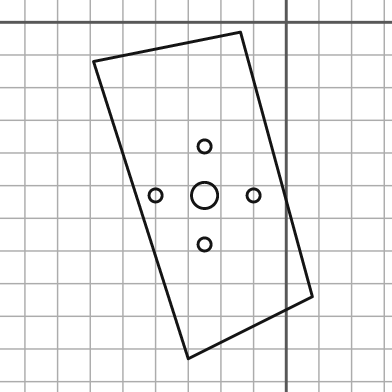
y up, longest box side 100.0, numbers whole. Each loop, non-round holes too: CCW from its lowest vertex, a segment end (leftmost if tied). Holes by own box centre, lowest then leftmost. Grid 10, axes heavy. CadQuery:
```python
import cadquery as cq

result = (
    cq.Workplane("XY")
    .moveTo(-30.0, -103.0)
    .lineTo(8.0, -84.0)
    .lineTo(-14.0, -3.0)
    .lineTo(-59.0, -12.0)
    .close()
    .moveTo(-25.0, -68.0)
    .circle(2.0)
    .moveTo(-40.0, -53.0)
    .circle(2.0)
    .moveTo(-25.0, -53.0)
    .circle(4.0)
    .moveTo(-10.0, -53.0)
    .circle(2.0)
    .moveTo(-25.0, -38.0)
    .circle(2.0)
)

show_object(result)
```